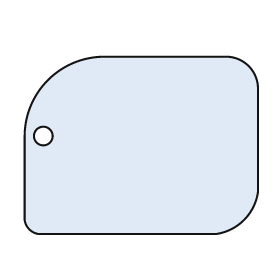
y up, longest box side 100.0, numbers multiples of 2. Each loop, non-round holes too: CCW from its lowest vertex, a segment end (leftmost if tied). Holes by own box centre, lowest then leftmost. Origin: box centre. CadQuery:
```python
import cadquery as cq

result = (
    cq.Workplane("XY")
    .moveTo(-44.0, -38.0)
    .lineTo(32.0, -38.0)
    .threePointArc((44.0, -32.0), (50.0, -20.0))
    .lineTo(50.0, 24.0)
    .threePointArc((46.0, 34.0), (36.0, 38.0))
    .lineTo(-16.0, 38.0)
    .threePointArc((-40.0, 28.0), (-50.0, 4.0))
    .lineTo(-50.0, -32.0)
    .threePointArc((-48.0, -36.0), (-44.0, -38.0))
    .close()
    .moveTo(-42.0, 4.0)
    .circle(4.0)
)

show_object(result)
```